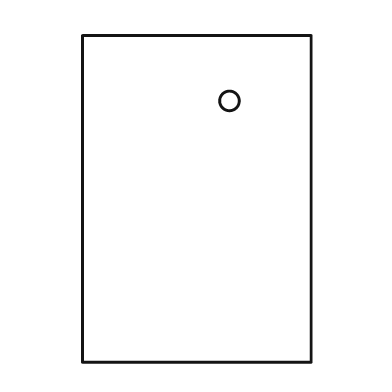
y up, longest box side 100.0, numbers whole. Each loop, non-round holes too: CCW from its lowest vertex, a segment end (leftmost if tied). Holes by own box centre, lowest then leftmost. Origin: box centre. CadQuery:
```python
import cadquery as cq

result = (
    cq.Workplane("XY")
    .moveTo(-35.0, -50.0)
    .lineTo(35.0, -50.0)
    .lineTo(35.0, 50.0)
    .lineTo(-35.0, 50.0)
    .close()
    .moveTo(10.0, 30.0)
    .circle(3.0)
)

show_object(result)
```